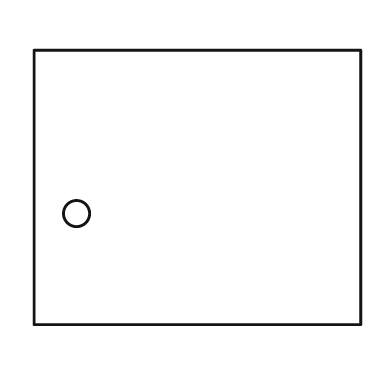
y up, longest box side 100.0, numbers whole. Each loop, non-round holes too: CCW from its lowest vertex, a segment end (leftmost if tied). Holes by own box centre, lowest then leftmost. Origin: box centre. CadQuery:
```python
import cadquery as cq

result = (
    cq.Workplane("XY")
    .moveTo(-50.0, -42.0)
    .lineTo(50.0, -42.0)
    .lineTo(50.0, 42.0)
    .lineTo(-50.0, 42.0)
    .close()
    .moveTo(-37.0, -8.0)
    .circle(4.0)
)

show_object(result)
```